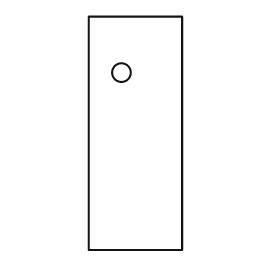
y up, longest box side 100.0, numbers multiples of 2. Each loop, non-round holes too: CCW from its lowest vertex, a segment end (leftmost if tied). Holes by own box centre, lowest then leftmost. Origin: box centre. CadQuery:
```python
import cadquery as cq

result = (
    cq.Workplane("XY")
    .moveTo(-20.0, -50.0)
    .lineTo(20.0, -50.0)
    .lineTo(20.0, 50.0)
    .lineTo(-20.0, 50.0)
    .close()
    .moveTo(-6.0, 26.0)
    .circle(4.0)
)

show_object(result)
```